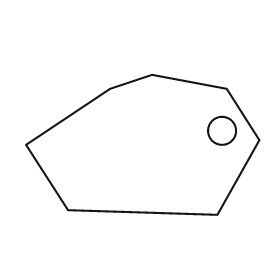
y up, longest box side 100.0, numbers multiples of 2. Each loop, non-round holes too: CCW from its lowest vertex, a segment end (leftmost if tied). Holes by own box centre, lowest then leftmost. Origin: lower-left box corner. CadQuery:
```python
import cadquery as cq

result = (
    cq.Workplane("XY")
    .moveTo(82.0, 0.0)
    .lineTo(100.0, 32.0)
    .lineTo(86.0, 54.0)
    .lineTo(54.0, 60.0)
    .lineTo(36.0, 54.0)
    .lineTo(0.0, 30.0)
    .lineTo(18.0, 2.0)
    .close()
    .moveTo(84.0, 36.0)
    .circle(6.0)
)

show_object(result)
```